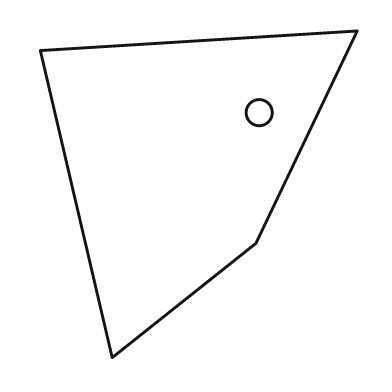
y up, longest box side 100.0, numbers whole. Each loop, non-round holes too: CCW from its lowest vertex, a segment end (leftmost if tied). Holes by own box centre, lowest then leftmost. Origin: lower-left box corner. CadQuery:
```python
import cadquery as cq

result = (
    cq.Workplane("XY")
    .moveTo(22.0, 0.0)
    .lineTo(66.0, 35.0)
    .lineTo(97.0, 100.0)
    .lineTo(0.0, 94.0)
    .close()
    .moveTo(67.0, 75.0)
    .circle(4.0)
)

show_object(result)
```